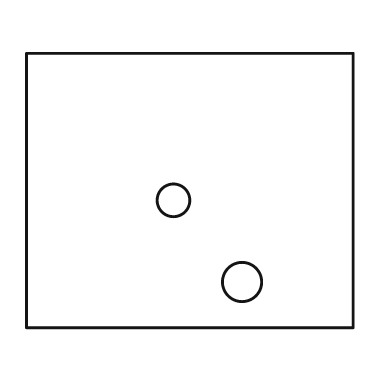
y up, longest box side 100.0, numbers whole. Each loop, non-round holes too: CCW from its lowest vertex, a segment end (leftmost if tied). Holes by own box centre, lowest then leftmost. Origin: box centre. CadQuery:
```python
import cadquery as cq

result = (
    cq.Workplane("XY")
    .moveTo(-50.0, -42.0)
    .lineTo(50.0, -42.0)
    .lineTo(50.0, 42.0)
    .lineTo(-50.0, 42.0)
    .close()
    .moveTo(16.0, -28.0)
    .circle(6.0)
    .moveTo(-5.0, -3.0)
    .circle(5.0)
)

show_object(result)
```